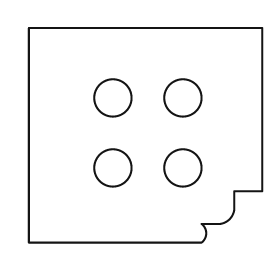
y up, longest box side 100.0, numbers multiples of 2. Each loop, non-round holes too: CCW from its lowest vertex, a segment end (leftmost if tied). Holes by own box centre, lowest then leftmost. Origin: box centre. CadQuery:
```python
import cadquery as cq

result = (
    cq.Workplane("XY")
    .moveTo(-50.0, -46.0)
    .lineTo(24.0, -46.0)
    .threePointArc((26.0, -42.0), (24.0, -38.0))
    .lineTo(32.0, -38.0)
    .threePointArc((36.0, -36.0), (38.0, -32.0))
    .lineTo(38.0, -24.0)
    .lineTo(50.0, -24.0)
    .lineTo(50.0, 46.0)
    .lineTo(-50.0, 46.0)
    .close()
    .moveTo(-14.0, -14.0)
    .circle(8.0)
    .moveTo(16.0, -14.0)
    .circle(8.0)
    .moveTo(-14.0, 16.0)
    .circle(8.0)
    .moveTo(16.0, 16.0)
    .circle(8.0)
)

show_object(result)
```